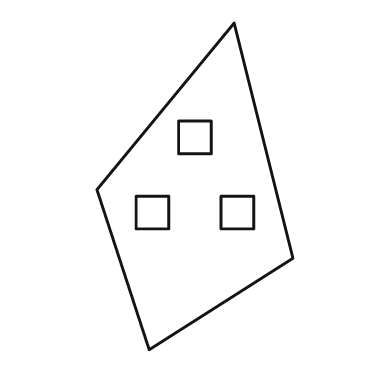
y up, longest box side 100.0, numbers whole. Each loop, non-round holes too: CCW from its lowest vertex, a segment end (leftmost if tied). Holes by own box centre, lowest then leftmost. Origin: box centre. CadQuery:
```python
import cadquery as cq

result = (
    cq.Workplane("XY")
    .moveTo(-14.0, -50.0)
    .lineTo(30.0, -22.0)
    .lineTo(12.0, 50.0)
    .lineTo(-30.0, -1.0)
    .close()
    .moveTo(-18.0, -13.0)
    .lineTo(-8.0, -13.0)
    .lineTo(-8.0, -3.0)
    .lineTo(-18.0, -3.0)
    .close()
    .moveTo(8.0, -13.0)
    .lineTo(18.0, -13.0)
    .lineTo(18.0, -3.0)
    .lineTo(8.0, -3.0)
    .close()
    .moveTo(-5.0, 10.0)
    .lineTo(5.0, 10.0)
    .lineTo(5.0, 20.0)
    .lineTo(-5.0, 20.0)
    .close()
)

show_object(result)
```